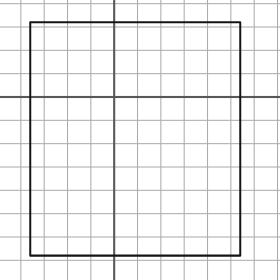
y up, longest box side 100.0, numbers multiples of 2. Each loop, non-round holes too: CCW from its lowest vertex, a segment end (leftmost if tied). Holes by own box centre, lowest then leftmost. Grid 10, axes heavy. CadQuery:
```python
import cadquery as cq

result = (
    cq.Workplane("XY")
    .moveTo(-36.0, -68.0)
    .lineTo(54.0, -68.0)
    .lineTo(54.0, 32.0)
    .lineTo(-36.0, 32.0)
    .close()
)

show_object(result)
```